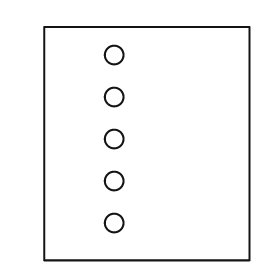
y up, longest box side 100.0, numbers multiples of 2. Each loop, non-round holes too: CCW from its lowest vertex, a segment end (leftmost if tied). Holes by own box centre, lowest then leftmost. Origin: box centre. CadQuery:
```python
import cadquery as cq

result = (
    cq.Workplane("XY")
    .moveTo(-44.0, -50.0)
    .lineTo(44.0, -50.0)
    .lineTo(44.0, 50.0)
    .lineTo(-44.0, 50.0)
    .close()
    .moveTo(-14.0, -34.0)
    .circle(4.0)
    .moveTo(-14.0, -16.0)
    .circle(4.0)
    .moveTo(-14.0, 2.0)
    .circle(4.0)
    .moveTo(-14.0, 20.0)
    .circle(4.0)
    .moveTo(-14.0, 38.0)
    .circle(4.0)
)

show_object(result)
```